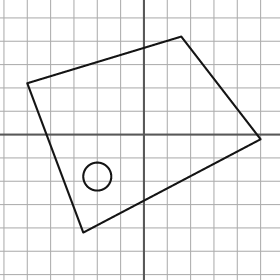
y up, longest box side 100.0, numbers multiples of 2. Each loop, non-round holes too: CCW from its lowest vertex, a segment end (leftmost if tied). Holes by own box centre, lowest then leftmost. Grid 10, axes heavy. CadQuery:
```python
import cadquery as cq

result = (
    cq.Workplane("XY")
    .moveTo(-26.0, -42.0)
    .lineTo(50.0, -2.0)
    .lineTo(16.0, 42.0)
    .lineTo(-50.0, 22.0)
    .close()
    .moveTo(-20.0, -18.0)
    .circle(6.0)
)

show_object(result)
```